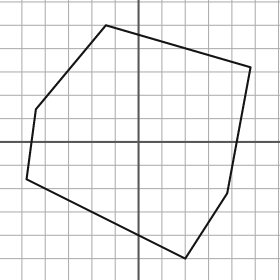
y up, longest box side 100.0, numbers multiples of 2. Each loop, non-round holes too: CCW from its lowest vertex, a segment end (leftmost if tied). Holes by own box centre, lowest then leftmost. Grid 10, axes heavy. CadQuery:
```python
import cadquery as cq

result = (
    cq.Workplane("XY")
    .moveTo(20.0, -50.0)
    .lineTo(38.0, -22.0)
    .lineTo(48.0, 32.0)
    .lineTo(-14.0, 50.0)
    .lineTo(-44.0, 14.0)
    .lineTo(-48.0, -16.0)
    .close()
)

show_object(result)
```